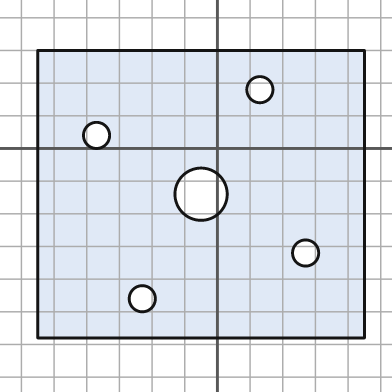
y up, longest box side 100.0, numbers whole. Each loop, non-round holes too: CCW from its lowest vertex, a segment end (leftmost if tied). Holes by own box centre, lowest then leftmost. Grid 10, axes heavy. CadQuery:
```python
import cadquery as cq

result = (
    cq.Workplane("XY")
    .moveTo(-55.0, -58.0)
    .lineTo(45.0, -58.0)
    .lineTo(45.0, 30.0)
    .lineTo(-55.0, 30.0)
    .close()
    .moveTo(-23.0, -46.0)
    .circle(4.0)
    .moveTo(27.0, -32.0)
    .circle(4.0)
    .moveTo(-5.0, -14.0)
    .circle(8.0)
    .moveTo(-37.0, 4.0)
    .circle(4.0)
    .moveTo(13.0, 18.0)
    .circle(4.0)
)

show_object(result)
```